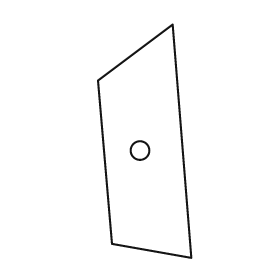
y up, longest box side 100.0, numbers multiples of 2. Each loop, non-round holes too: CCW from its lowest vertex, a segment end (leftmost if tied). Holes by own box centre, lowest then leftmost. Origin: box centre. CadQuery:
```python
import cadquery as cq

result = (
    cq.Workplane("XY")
    .moveTo(20.0, -50.0)
    .lineTo(12.0, 50.0)
    .lineTo(-20.0, 26.0)
    .lineTo(-14.0, -44.0)
    .close()
    .moveTo(-2.0, -4.0)
    .circle(4.0)
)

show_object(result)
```